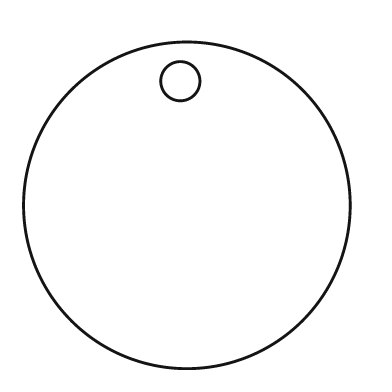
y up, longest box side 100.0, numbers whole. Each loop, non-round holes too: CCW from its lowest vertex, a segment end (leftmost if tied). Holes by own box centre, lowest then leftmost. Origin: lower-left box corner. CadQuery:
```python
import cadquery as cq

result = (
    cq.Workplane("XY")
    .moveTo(50.0, 50.0)
    .circle(50.0)
    .moveTo(48.0, 88.0)
    .circle(6.0)
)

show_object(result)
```